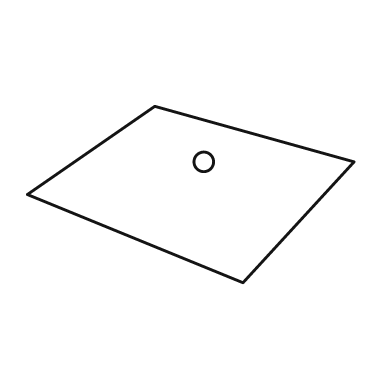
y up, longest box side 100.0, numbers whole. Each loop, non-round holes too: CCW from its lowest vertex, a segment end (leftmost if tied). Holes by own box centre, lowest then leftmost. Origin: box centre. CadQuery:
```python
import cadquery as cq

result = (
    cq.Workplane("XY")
    .moveTo(16.0, -27.0)
    .lineTo(50.0, 10.0)
    .lineTo(-11.0, 27.0)
    .lineTo(-50.0, 0.0)
    .close()
    .moveTo(4.0, 10.0)
    .circle(3.0)
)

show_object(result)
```